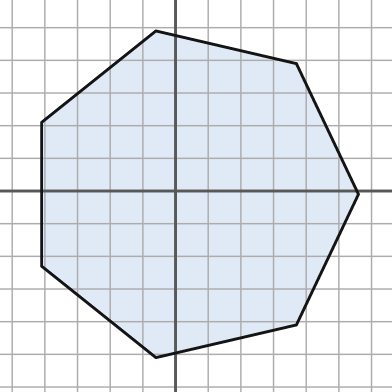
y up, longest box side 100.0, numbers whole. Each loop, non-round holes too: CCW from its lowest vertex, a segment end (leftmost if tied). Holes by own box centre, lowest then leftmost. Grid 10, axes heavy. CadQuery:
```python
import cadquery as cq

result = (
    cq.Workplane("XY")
    .moveTo(-6.0, -51.0)
    .lineTo(37.0, -41.0)
    .lineTo(56.0, -1.0)
    .lineTo(37.0, 39.0)
    .lineTo(-6.0, 49.0)
    .lineTo(-41.0, 21.0)
    .lineTo(-41.0, -23.0)
    .close()
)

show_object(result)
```